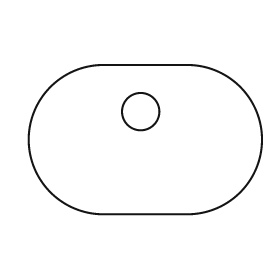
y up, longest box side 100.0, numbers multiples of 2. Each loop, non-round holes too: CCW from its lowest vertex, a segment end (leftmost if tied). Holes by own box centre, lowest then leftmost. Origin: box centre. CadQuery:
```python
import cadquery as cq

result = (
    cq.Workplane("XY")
    .moveTo(-18.0, -32.0)
    .lineTo(18.0, -32.0)
    .threePointArc((50.0, 0.0), (18.0, 32.0))
    .lineTo(-18.0, 32.0)
    .threePointArc((-50.0, 0.0), (-18.0, -32.0))
    .close()
    .moveTo(-2.0, 12.0)
    .circle(8.0)
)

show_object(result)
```